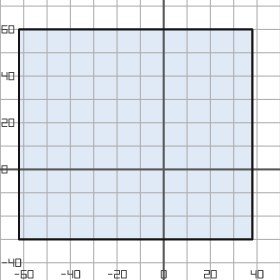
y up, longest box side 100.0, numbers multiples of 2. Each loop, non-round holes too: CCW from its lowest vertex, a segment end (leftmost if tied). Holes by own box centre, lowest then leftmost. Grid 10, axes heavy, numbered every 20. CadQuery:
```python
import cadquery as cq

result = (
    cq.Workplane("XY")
    .moveTo(-62.0, -30.0)
    .lineTo(38.0, -30.0)
    .lineTo(38.0, 60.0)
    .lineTo(-62.0, 60.0)
    .close()
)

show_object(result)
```